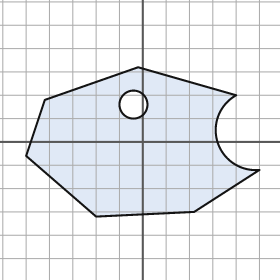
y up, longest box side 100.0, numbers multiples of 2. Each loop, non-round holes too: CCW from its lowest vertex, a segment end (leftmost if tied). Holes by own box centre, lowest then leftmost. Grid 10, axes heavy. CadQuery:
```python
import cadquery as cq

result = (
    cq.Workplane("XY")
    .moveTo(-20.0, -32.0)
    .lineTo(22.0, -30.0)
    .lineTo(50.0, -12.0)
    .threePointArc((32.0, 0.0), (40.0, 20.0))
    .lineTo(-2.0, 32.0)
    .lineTo(-42.0, 18.0)
    .lineTo(-50.0, -6.0)
    .close()
    .moveTo(-4.0, 16.0)
    .circle(6.0)
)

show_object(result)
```